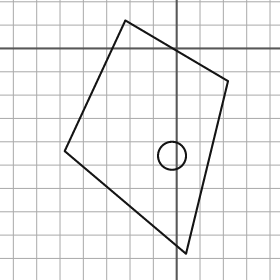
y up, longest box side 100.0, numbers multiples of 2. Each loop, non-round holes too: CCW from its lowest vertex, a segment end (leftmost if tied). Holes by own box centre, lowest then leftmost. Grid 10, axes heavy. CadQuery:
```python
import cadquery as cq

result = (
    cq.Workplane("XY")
    .moveTo(4.0, -88.0)
    .lineTo(22.0, -14.0)
    .lineTo(-22.0, 12.0)
    .lineTo(-48.0, -44.0)
    .close()
    .moveTo(-2.0, -46.0)
    .circle(6.0)
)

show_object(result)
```